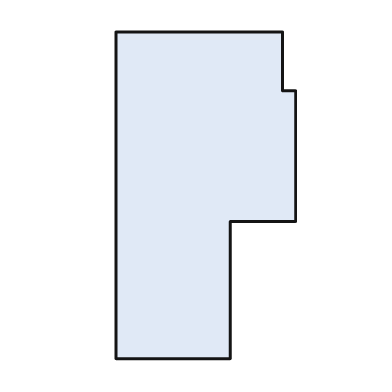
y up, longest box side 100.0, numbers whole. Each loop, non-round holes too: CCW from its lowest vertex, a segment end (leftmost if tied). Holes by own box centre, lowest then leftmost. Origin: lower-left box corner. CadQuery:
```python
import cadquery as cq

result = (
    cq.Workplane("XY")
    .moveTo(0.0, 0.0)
    .lineTo(35.0, 0.0)
    .lineTo(35.0, 42.0)
    .lineTo(55.0, 42.0)
    .lineTo(55.0, 82.0)
    .lineTo(51.0, 82.0)
    .lineTo(51.0, 100.0)
    .lineTo(0.0, 100.0)
    .close()
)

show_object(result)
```